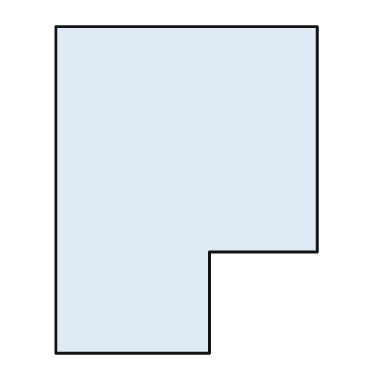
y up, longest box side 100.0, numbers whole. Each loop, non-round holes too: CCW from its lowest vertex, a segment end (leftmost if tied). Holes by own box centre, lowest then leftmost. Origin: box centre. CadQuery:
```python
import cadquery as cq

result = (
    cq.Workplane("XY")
    .moveTo(-40.0, -50.0)
    .lineTo(7.0, -50.0)
    .lineTo(7.0, -19.0)
    .lineTo(40.0, -19.0)
    .lineTo(40.0, 50.0)
    .lineTo(-40.0, 50.0)
    .close()
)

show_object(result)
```